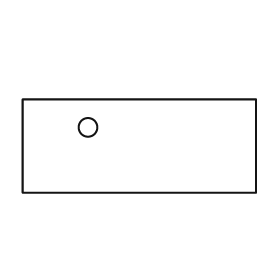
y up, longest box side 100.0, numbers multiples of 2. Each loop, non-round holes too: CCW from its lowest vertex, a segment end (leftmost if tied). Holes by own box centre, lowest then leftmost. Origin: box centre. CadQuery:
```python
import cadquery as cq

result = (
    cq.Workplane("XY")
    .moveTo(-50.0, -20.0)
    .lineTo(50.0, -20.0)
    .lineTo(50.0, 20.0)
    .lineTo(-50.0, 20.0)
    .close()
    .moveTo(-22.0, 8.0)
    .circle(4.0)
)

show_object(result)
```